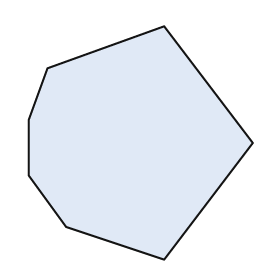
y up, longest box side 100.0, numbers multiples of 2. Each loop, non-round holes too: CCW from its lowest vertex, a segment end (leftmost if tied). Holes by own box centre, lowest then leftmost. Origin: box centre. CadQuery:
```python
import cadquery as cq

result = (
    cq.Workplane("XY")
    .moveTo(10.0, -50.0)
    .lineTo(48.0, 0.0)
    .lineTo(10.0, 50.0)
    .lineTo(-40.0, 32.0)
    .lineTo(-48.0, 10.0)
    .lineTo(-48.0, -14.0)
    .lineTo(-32.0, -36.0)
    .close()
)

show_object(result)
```